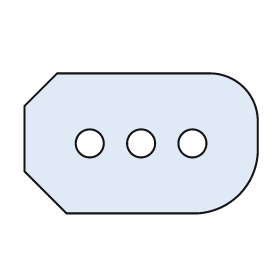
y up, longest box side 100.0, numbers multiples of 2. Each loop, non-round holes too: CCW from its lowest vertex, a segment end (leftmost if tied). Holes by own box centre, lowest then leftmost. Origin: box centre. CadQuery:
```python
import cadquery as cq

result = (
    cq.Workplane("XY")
    .moveTo(-32.0, -30.0)
    .lineTo(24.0, -30.0)
    .threePointArc((42.0, -22.0), (50.0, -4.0))
    .lineTo(50.0, 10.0)
    .threePointArc((44.0, 24.0), (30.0, 30.0))
    .lineTo(-36.0, 30.0)
    .lineTo(-50.0, 16.0)
    .lineTo(-50.0, -12.0)
    .close()
    .moveTo(-22.0, 0.0)
    .circle(6.0)
    .moveTo(0.0, 0.0)
    .circle(6.0)
    .moveTo(22.0, 0.0)
    .circle(6.0)
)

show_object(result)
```